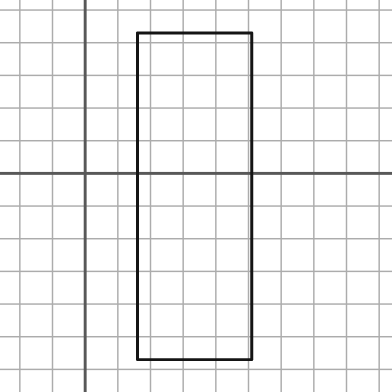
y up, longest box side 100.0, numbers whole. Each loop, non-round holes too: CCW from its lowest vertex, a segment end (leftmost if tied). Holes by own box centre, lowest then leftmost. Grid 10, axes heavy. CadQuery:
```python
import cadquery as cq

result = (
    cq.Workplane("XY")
    .moveTo(16.0, -57.0)
    .lineTo(51.0, -57.0)
    .lineTo(51.0, 43.0)
    .lineTo(16.0, 43.0)
    .close()
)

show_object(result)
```